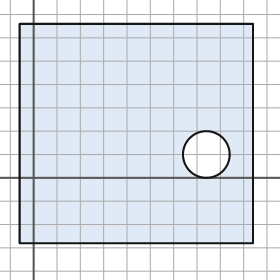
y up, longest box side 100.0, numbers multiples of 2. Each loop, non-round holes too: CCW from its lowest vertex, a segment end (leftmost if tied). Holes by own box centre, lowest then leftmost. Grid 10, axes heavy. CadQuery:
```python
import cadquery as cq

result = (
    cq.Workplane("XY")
    .moveTo(-6.0, -28.0)
    .lineTo(94.0, -28.0)
    .lineTo(94.0, 66.0)
    .lineTo(-6.0, 66.0)
    .close()
    .moveTo(74.0, 10.0)
    .circle(10.0)
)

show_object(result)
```